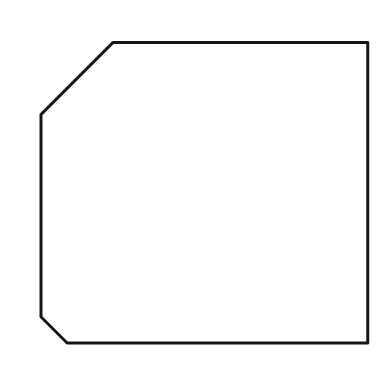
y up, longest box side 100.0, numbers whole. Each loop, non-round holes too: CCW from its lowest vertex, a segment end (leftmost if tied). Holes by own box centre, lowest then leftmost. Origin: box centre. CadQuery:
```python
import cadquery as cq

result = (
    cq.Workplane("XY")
    .moveTo(-42.0, -46.0)
    .lineTo(50.0, -46.0)
    .lineTo(50.0, 46.0)
    .lineTo(-28.0, 46.0)
    .lineTo(-50.0, 24.0)
    .lineTo(-50.0, -38.0)
    .close()
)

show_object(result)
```